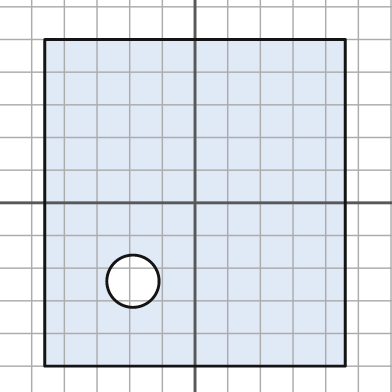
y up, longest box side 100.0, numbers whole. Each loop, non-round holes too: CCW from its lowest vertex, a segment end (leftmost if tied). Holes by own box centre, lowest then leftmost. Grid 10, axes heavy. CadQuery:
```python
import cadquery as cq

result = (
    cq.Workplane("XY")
    .moveTo(-46.0, -50.0)
    .lineTo(46.0, -50.0)
    .lineTo(46.0, 50.0)
    .lineTo(-46.0, 50.0)
    .close()
    .moveTo(-19.0, -24.0)
    .circle(8.0)
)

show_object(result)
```